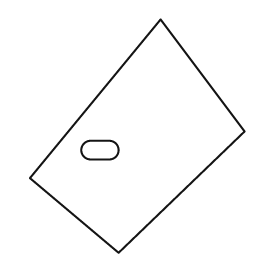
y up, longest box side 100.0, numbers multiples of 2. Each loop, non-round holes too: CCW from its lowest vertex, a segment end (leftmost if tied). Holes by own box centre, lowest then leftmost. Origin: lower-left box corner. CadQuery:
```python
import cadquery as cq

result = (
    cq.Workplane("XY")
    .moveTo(38.0, 0.0)
    .lineTo(92.0, 52.0)
    .lineTo(56.0, 100.0)
    .lineTo(0.0, 32.0)
    .close()
    .moveTo(26.0, 40.0)
    .lineTo(34.0, 40.0)
    .threePointArc((38.0, 44.0), (34.0, 48.0))
    .lineTo(26.0, 48.0)
    .threePointArc((22.0, 44.0), (26.0, 40.0))
    .close()
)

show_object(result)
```